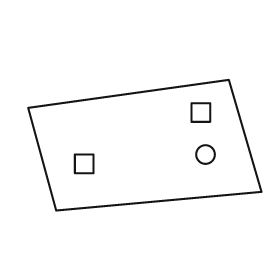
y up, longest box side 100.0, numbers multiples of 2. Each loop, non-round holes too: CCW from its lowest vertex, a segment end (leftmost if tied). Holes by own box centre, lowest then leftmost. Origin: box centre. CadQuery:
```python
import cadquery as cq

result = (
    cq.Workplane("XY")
    .moveTo(-38.0, -28.0)
    .lineTo(50.0, -20.0)
    .lineTo(36.0, 28.0)
    .lineTo(-50.0, 16.0)
    .close()
    .moveTo(-30.0, -12.0)
    .lineTo(-22.0, -12.0)
    .lineTo(-22.0, -4.0)
    .lineTo(-30.0, -4.0)
    .close()
    .moveTo(26.0, -4.0)
    .circle(4.0)
    .moveTo(20.0, 10.0)
    .lineTo(28.0, 10.0)
    .lineTo(28.0, 18.0)
    .lineTo(20.0, 18.0)
    .close()
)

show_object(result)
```